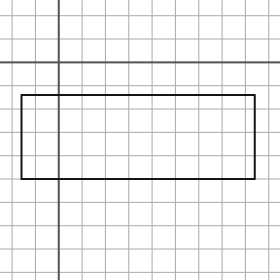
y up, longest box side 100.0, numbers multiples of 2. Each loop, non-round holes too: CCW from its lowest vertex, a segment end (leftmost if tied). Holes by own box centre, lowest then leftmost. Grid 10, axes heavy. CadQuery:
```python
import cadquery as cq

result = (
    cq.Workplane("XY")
    .moveTo(-16.0, -50.0)
    .lineTo(84.0, -50.0)
    .lineTo(84.0, -14.0)
    .lineTo(-16.0, -14.0)
    .close()
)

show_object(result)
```